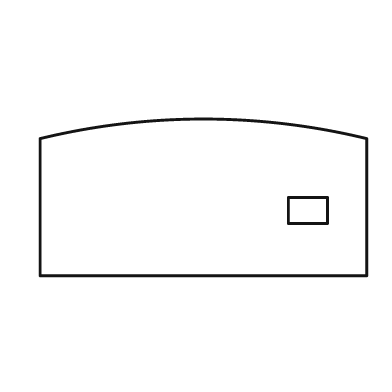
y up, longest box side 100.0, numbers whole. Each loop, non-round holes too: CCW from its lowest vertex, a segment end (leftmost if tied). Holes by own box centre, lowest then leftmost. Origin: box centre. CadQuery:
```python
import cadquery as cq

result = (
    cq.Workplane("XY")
    .moveTo(-50.0, -24.0)
    .lineTo(50.0, -24.0)
    .lineTo(50.0, 18.0)
    .threePointArc((0.0, 24.0), (-50.0, 18.0))
    .close()
    .moveTo(26.0, -8.0)
    .lineTo(38.0, -8.0)
    .lineTo(38.0, 0.0)
    .lineTo(26.0, 0.0)
    .close()
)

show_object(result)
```